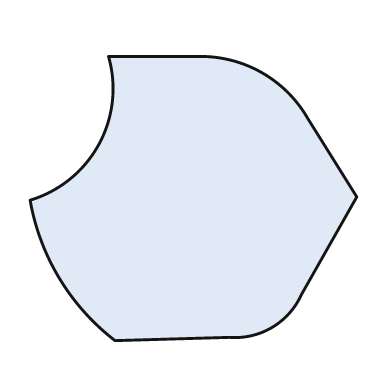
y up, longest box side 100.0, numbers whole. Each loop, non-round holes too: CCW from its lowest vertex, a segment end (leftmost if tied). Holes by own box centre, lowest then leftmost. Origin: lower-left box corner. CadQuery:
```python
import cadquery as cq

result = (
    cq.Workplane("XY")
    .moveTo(26.0, 0.0)
    .lineTo(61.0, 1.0)
    .threePointArc((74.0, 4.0), (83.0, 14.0))
    .lineTo(100.0, 44.0)
    .lineTo(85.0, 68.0)
    .threePointArc((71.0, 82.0), (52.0, 87.0))
    .lineTo(24.0, 87.0)
    .threePointArc((21.0, 60.0), (0.0, 43.0))
    .threePointArc((9.0, 19.0), (26.0, 0.0))
    .close()
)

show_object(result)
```